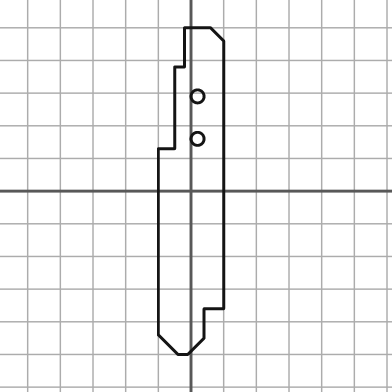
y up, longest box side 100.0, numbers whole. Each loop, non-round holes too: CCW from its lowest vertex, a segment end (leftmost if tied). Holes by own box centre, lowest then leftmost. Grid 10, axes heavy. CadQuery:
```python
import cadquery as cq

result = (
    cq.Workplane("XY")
    .moveTo(-4.0, -50.0)
    .lineTo(-1.0, -50.0)
    .lineTo(4.0, -45.0)
    .lineTo(4.0, -36.0)
    .lineTo(10.0, -36.0)
    .lineTo(10.0, 46.0)
    .lineTo(6.0, 50.0)
    .lineTo(-2.0, 50.0)
    .lineTo(-2.0, 38.0)
    .lineTo(-5.0, 38.0)
    .lineTo(-5.0, 13.0)
    .lineTo(-10.0, 13.0)
    .lineTo(-10.0, -44.0)
    .close()
    .moveTo(2.0, 16.0)
    .circle(2.0)
    .moveTo(2.0, 29.0)
    .circle(2.0)
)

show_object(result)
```